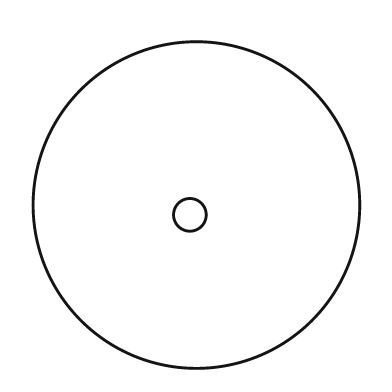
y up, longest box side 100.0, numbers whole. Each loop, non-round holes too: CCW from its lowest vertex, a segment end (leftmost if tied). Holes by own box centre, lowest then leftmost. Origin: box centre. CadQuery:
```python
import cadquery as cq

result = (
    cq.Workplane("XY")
    .moveTo(0.0, 0.0)
    .circle(50.0)
    .moveTo(-2.0, -3.0)
    .circle(5.0)
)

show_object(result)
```